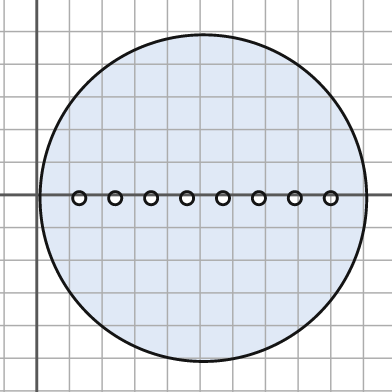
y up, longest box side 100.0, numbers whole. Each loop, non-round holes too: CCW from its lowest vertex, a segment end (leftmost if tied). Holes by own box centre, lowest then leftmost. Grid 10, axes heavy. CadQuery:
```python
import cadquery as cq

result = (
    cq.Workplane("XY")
    .moveTo(51.0, -1.0)
    .circle(50.0)
    .moveTo(13.0, -1.0)
    .circle(2.0)
    .moveTo(24.0, -1.0)
    .circle(2.0)
    .moveTo(35.0, -1.0)
    .circle(2.0)
    .moveTo(46.0, -1.0)
    .circle(2.0)
    .moveTo(57.0, -1.0)
    .circle(2.0)
    .moveTo(68.0, -1.0)
    .circle(2.0)
    .moveTo(79.0, -1.0)
    .circle(2.0)
    .moveTo(90.0, -1.0)
    .circle(2.0)
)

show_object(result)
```